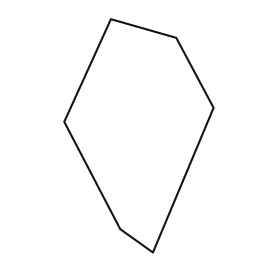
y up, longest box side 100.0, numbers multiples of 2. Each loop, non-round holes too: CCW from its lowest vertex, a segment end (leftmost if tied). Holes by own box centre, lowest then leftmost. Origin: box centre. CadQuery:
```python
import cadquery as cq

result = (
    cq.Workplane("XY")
    .moveTo(6.0, -50.0)
    .lineTo(32.0, 12.0)
    .lineTo(16.0, 42.0)
    .lineTo(-12.0, 50.0)
    .lineTo(-32.0, 6.0)
    .lineTo(-8.0, -40.0)
    .close()
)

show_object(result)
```